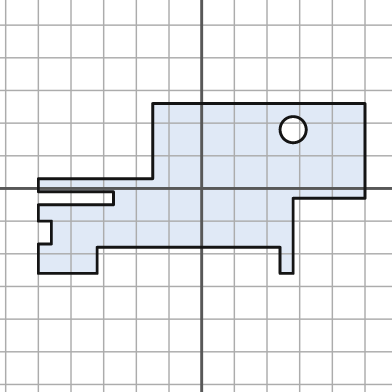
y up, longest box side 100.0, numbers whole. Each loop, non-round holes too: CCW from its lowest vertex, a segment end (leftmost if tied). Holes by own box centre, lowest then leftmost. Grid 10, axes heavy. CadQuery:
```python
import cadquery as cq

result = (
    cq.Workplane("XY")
    .moveTo(-50.0, -26.0)
    .lineTo(-32.0, -26.0)
    .lineTo(-32.0, -18.0)
    .lineTo(24.0, -18.0)
    .lineTo(24.0, -26.0)
    .lineTo(28.0, -26.0)
    .lineTo(28.0, -3.0)
    .lineTo(50.0, -3.0)
    .lineTo(50.0, 26.0)
    .lineTo(-15.0, 26.0)
    .lineTo(-15.0, 3.0)
    .lineTo(-50.0, 3.0)
    .lineTo(-50.0, -1.0)
    .lineTo(-27.0, -1.0)
    .lineTo(-27.0, -5.0)
    .lineTo(-50.0, -5.0)
    .lineTo(-50.0, -10.0)
    .lineTo(-46.0, -10.0)
    .lineTo(-46.0, -17.0)
    .lineTo(-50.0, -17.0)
    .close()
    .moveTo(28.0, 18.0)
    .circle(4.0)
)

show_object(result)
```